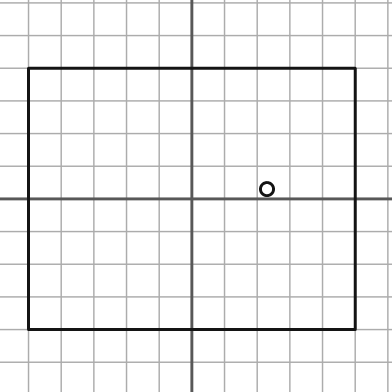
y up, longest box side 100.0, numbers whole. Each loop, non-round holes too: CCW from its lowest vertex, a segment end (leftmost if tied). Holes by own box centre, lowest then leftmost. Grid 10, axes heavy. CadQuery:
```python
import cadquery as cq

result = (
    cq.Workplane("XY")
    .moveTo(-50.0, -40.0)
    .lineTo(50.0, -40.0)
    .lineTo(50.0, 40.0)
    .lineTo(-50.0, 40.0)
    .close()
    .moveTo(23.0, 3.0)
    .circle(2.0)
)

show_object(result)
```